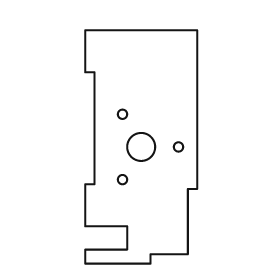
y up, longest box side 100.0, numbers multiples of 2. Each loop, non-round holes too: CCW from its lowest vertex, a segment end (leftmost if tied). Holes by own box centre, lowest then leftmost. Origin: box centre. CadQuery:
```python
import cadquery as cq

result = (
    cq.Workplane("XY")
    .moveTo(-24.0, -50.0)
    .lineTo(4.0, -50.0)
    .lineTo(4.0, -46.0)
    .lineTo(20.0, -46.0)
    .lineTo(20.0, -18.0)
    .lineTo(24.0, -18.0)
    .lineTo(24.0, 50.0)
    .lineTo(-24.0, 50.0)
    .lineTo(-24.0, 32.0)
    .lineTo(-20.0, 32.0)
    .lineTo(-20.0, -16.0)
    .lineTo(-24.0, -16.0)
    .lineTo(-24.0, -34.0)
    .lineTo(-6.0, -34.0)
    .lineTo(-6.0, -44.0)
    .lineTo(-24.0, -44.0)
    .close()
    .moveTo(-8.0, -14.0)
    .circle(2.0)
    .moveTo(0.0, 0.0)
    .circle(6.0)
    .moveTo(16.0, 0.0)
    .circle(2.0)
    .moveTo(-8.0, 14.0)
    .circle(2.0)
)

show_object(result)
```